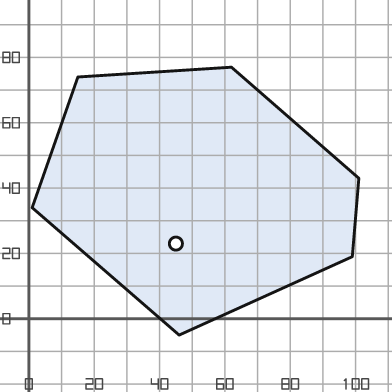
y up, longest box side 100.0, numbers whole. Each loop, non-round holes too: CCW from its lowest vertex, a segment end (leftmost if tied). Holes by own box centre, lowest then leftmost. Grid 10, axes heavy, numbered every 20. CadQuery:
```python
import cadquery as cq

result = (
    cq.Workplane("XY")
    .moveTo(46.0, -5.0)
    .lineTo(99.0, 19.0)
    .lineTo(101.0, 43.0)
    .lineTo(62.0, 77.0)
    .lineTo(15.0, 74.0)
    .lineTo(1.0, 34.0)
    .close()
    .moveTo(45.0, 23.0)
    .circle(2.0)
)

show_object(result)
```